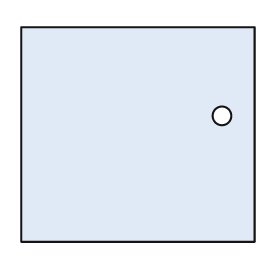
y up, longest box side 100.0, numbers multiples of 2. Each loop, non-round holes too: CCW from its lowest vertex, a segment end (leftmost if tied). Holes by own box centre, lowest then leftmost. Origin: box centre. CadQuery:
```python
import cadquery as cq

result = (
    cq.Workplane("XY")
    .moveTo(-50.0, -46.0)
    .lineTo(50.0, -46.0)
    .lineTo(50.0, 46.0)
    .lineTo(-50.0, 46.0)
    .close()
    .moveTo(36.0, 8.0)
    .circle(4.0)
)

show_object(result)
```